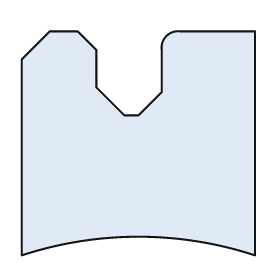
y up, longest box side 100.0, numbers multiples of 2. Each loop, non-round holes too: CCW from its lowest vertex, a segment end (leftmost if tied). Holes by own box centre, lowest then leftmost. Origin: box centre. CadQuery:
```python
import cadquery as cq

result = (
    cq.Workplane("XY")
    .moveTo(-50.0, -48.0)
    .threePointArc((0.0, -40.0), (50.0, -48.0))
    .lineTo(50.0, 48.0)
    .lineTo(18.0, 48.0)
    .threePointArc((12.0, 46.0), (10.0, 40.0))
    .lineTo(10.0, 22.0)
    .lineTo(0.0, 12.0)
    .lineTo(-6.0, 12.0)
    .lineTo(-18.0, 24.0)
    .lineTo(-18.0, 40.0)
    .lineTo(-26.0, 48.0)
    .lineTo(-38.0, 48.0)
    .lineTo(-50.0, 36.0)
    .close()
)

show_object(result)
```